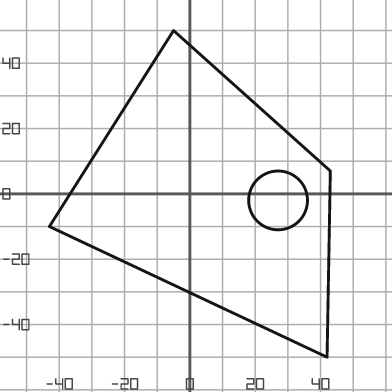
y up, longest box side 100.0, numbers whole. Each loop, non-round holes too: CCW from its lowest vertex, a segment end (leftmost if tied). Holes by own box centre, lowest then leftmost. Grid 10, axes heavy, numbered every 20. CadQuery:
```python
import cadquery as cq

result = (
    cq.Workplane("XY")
    .moveTo(42.0, -50.0)
    .lineTo(43.0, 7.0)
    .lineTo(-5.0, 50.0)
    .lineTo(-43.0, -10.0)
    .close()
    .moveTo(27.0, -2.0)
    .circle(9.0)
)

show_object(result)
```